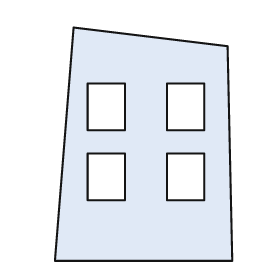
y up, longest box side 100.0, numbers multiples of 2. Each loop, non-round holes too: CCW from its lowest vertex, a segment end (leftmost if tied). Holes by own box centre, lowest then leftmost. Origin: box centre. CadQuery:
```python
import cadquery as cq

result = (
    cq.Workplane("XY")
    .moveTo(-38.0, -50.0)
    .lineTo(38.0, -50.0)
    .lineTo(36.0, 42.0)
    .lineTo(-30.0, 50.0)
    .close()
    .moveTo(-24.0, -24.0)
    .lineTo(-8.0, -24.0)
    .lineTo(-8.0, -4.0)
    .lineTo(-24.0, -4.0)
    .close()
    .moveTo(10.0, -24.0)
    .lineTo(26.0, -24.0)
    .lineTo(26.0, -4.0)
    .lineTo(10.0, -4.0)
    .close()
    .moveTo(-24.0, 6.0)
    .lineTo(-8.0, 6.0)
    .lineTo(-8.0, 26.0)
    .lineTo(-24.0, 26.0)
    .close()
    .moveTo(10.0, 6.0)
    .lineTo(26.0, 6.0)
    .lineTo(26.0, 26.0)
    .lineTo(10.0, 26.0)
    .close()
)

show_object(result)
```